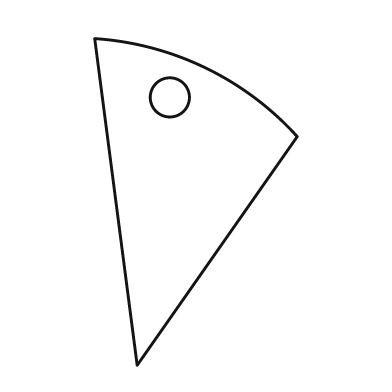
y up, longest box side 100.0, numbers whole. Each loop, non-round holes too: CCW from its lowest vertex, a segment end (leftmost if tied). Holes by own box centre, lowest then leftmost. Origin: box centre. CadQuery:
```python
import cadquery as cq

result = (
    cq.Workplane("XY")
    .moveTo(-18.0, -50.0)
    .lineTo(31.0, 20.0)
    .threePointArc((3.0, 41.0), (-31.0, 50.0))
    .close()
    .moveTo(-8.0, 32.0)
    .circle(6.0)
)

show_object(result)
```